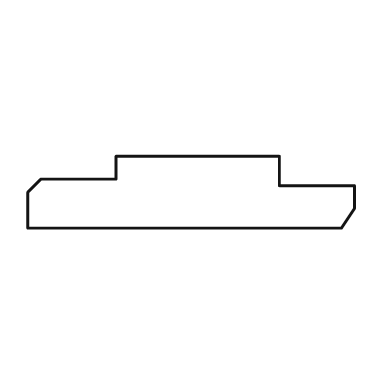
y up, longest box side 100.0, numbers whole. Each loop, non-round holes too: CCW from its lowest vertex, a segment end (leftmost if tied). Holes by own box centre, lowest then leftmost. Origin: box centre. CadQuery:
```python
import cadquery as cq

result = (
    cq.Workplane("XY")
    .moveTo(-50.0, -11.0)
    .lineTo(46.0, -11.0)
    .lineTo(50.0, -5.0)
    .lineTo(50.0, 2.0)
    .lineTo(27.0, 2.0)
    .lineTo(27.0, 11.0)
    .lineTo(-23.0, 11.0)
    .lineTo(-23.0, 4.0)
    .lineTo(-46.0, 4.0)
    .lineTo(-50.0, 0.0)
    .close()
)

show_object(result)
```